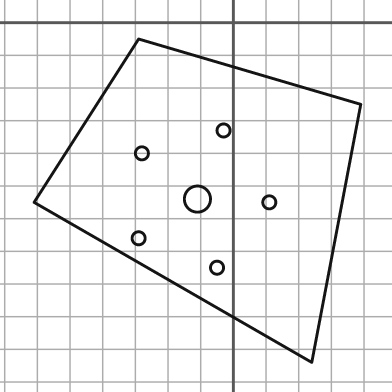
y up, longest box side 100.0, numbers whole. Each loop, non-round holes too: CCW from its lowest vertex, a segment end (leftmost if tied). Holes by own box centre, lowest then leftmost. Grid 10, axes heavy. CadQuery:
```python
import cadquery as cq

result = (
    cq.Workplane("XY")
    .moveTo(24.0, -104.0)
    .lineTo(39.0, -25.0)
    .lineTo(-29.0, -5.0)
    .lineTo(-61.0, -55.0)
    .close()
    .moveTo(-5.0, -75.0)
    .circle(2.0)
    .moveTo(-29.0, -66.0)
    .circle(2.0)
    .moveTo(11.0, -55.0)
    .circle(2.0)
    .moveTo(-11.0, -54.0)
    .circle(4.0)
    .moveTo(-28.0, -40.0)
    .circle(2.0)
    .moveTo(-3.0, -33.0)
    .circle(2.0)
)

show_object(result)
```